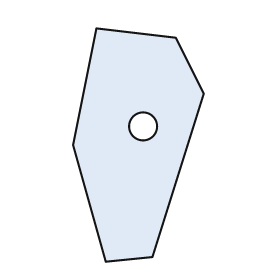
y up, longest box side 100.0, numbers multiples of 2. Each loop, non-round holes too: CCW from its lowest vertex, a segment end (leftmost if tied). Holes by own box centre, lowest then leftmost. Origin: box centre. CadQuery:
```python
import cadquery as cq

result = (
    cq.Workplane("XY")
    .moveTo(-14.0, -50.0)
    .lineTo(6.0, -48.0)
    .lineTo(28.0, 22.0)
    .lineTo(16.0, 46.0)
    .lineTo(-18.0, 50.0)
    .lineTo(-28.0, 0.0)
    .close()
    .moveTo(2.0, 8.0)
    .circle(6.0)
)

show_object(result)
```